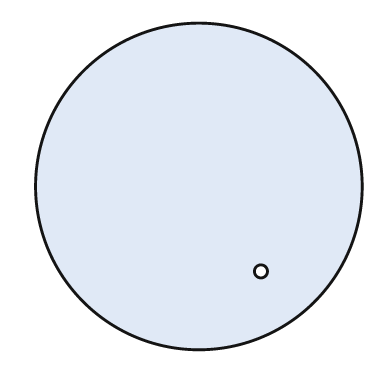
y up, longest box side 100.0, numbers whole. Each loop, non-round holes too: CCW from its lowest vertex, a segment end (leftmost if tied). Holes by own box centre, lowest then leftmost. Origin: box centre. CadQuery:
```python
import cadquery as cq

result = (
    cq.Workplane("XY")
    .moveTo(0.0, 0.0)
    .circle(50.0)
    .moveTo(19.0, -26.0)
    .circle(2.0)
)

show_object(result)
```